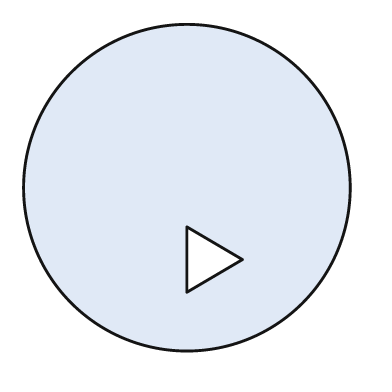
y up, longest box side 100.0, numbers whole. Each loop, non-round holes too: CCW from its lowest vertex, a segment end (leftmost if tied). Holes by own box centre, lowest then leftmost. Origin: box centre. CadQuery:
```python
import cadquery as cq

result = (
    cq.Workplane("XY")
    .moveTo(0.0, 0.0)
    .circle(50.0)
    .moveTo(0.0, -32.0)
    .lineTo(17.0, -22.0)
    .lineTo(0.0, -12.0)
    .close()
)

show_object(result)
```